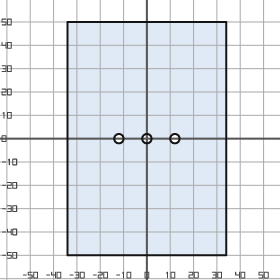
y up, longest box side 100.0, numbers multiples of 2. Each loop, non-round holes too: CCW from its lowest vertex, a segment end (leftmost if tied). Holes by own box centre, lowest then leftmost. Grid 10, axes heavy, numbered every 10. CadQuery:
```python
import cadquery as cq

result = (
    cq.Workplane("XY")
    .moveTo(-34.0, -50.0)
    .lineTo(34.0, -50.0)
    .lineTo(34.0, 50.0)
    .lineTo(-34.0, 50.0)
    .close()
    .moveTo(-12.0, 0.0)
    .circle(2.0)
    .moveTo(0.0, 0.0)
    .circle(2.0)
    .moveTo(12.0, 0.0)
    .circle(2.0)
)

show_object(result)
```